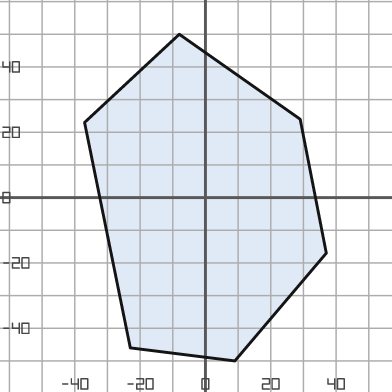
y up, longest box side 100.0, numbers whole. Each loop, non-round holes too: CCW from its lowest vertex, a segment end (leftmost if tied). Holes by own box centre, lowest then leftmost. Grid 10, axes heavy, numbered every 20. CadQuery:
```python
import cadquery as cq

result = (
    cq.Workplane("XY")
    .moveTo(9.0, -50.0)
    .lineTo(37.0, -17.0)
    .lineTo(29.0, 24.0)
    .lineTo(-8.0, 50.0)
    .lineTo(-37.0, 23.0)
    .lineTo(-23.0, -46.0)
    .close()
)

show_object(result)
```